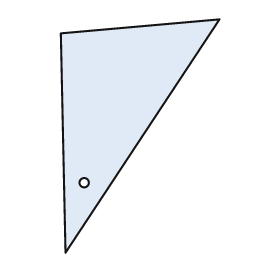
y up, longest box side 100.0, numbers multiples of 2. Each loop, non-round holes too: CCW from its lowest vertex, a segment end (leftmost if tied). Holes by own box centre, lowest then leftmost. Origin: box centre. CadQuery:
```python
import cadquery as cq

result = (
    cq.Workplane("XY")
    .moveTo(-32.0, -50.0)
    .lineTo(34.0, 50.0)
    .lineTo(-34.0, 44.0)
    .close()
    .moveTo(-24.0, -20.0)
    .circle(2.0)
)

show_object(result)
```